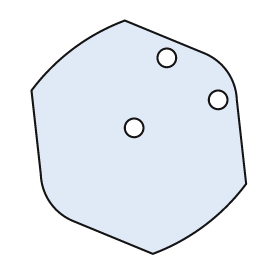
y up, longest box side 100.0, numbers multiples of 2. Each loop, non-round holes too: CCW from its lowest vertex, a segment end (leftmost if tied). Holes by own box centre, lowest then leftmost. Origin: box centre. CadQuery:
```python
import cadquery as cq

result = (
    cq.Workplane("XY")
    .moveTo(6.0, -50.0)
    .threePointArc((28.0, -38.0), (46.0, -20.0))
    .lineTo(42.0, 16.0)
    .threePointArc((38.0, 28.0), (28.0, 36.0))
    .lineTo(-6.0, 50.0)
    .threePointArc((-28.0, 38.0), (-46.0, 20.0))
    .lineTo(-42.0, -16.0)
    .threePointArc((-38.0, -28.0), (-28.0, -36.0))
    .close()
    .moveTo(-2.0, 4.0)
    .circle(4.0)
    .moveTo(34.0, 16.0)
    .circle(4.0)
    .moveTo(12.0, 34.0)
    .circle(4.0)
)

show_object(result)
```